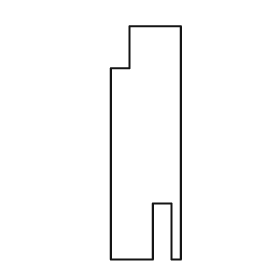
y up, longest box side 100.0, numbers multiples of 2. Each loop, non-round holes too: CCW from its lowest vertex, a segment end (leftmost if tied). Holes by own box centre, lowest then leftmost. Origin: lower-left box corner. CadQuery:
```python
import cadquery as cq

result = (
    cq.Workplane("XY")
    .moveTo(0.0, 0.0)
    .lineTo(18.0, 0.0)
    .lineTo(18.0, 24.0)
    .lineTo(26.0, 24.0)
    .lineTo(26.0, 0.0)
    .lineTo(30.0, 0.0)
    .lineTo(30.0, 100.0)
    .lineTo(8.0, 100.0)
    .lineTo(8.0, 82.0)
    .lineTo(0.0, 82.0)
    .close()
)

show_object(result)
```